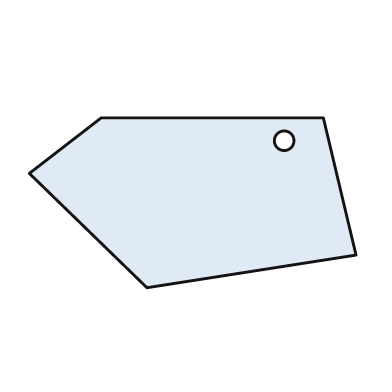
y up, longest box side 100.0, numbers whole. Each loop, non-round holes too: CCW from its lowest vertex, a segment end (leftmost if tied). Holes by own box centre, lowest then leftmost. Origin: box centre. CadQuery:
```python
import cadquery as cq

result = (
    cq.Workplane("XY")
    .moveTo(-14.0, -26.0)
    .lineTo(50.0, -16.0)
    .lineTo(40.0, 26.0)
    .lineTo(-28.0, 26.0)
    .lineTo(-50.0, 9.0)
    .close()
    .moveTo(28.0, 19.0)
    .circle(3.0)
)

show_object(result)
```